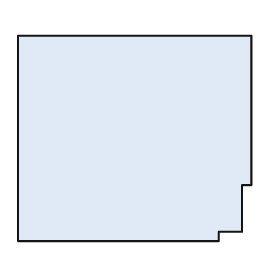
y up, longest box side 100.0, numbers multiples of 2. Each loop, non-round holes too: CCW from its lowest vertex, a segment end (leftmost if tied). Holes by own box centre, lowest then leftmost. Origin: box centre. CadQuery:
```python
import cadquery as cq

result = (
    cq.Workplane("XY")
    .moveTo(-50.0, -44.0)
    .lineTo(36.0, -44.0)
    .lineTo(36.0, -40.0)
    .lineTo(46.0, -40.0)
    .lineTo(46.0, -20.0)
    .lineTo(50.0, -20.0)
    .lineTo(50.0, 44.0)
    .lineTo(-50.0, 44.0)
    .close()
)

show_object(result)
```